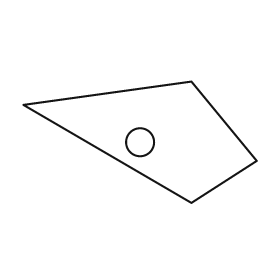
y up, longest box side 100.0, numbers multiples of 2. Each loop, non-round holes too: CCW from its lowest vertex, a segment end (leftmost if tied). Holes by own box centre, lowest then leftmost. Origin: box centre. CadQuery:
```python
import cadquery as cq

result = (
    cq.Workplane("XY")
    .moveTo(22.0, -26.0)
    .lineTo(50.0, -8.0)
    .lineTo(22.0, 26.0)
    .lineTo(-50.0, 16.0)
    .close()
    .moveTo(0.0, 0.0)
    .circle(6.0)
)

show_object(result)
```